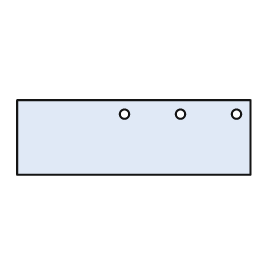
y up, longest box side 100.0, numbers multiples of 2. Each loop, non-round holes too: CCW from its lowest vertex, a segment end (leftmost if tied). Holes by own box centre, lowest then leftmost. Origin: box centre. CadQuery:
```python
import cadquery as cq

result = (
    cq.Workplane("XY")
    .moveTo(-50.0, -16.0)
    .lineTo(50.0, -16.0)
    .lineTo(50.0, 16.0)
    .lineTo(-50.0, 16.0)
    .close()
    .moveTo(-4.0, 10.0)
    .circle(2.0)
    .moveTo(20.0, 10.0)
    .circle(2.0)
    .moveTo(44.0, 10.0)
    .circle(2.0)
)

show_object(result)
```